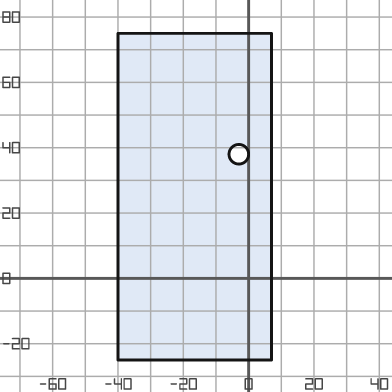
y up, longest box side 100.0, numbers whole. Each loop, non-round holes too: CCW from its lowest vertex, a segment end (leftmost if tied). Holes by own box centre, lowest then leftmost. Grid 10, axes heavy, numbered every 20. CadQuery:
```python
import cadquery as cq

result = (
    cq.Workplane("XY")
    .moveTo(-40.0, -25.0)
    .lineTo(7.0, -25.0)
    .lineTo(7.0, 75.0)
    .lineTo(-40.0, 75.0)
    .close()
    .moveTo(-3.0, 38.0)
    .circle(3.0)
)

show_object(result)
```